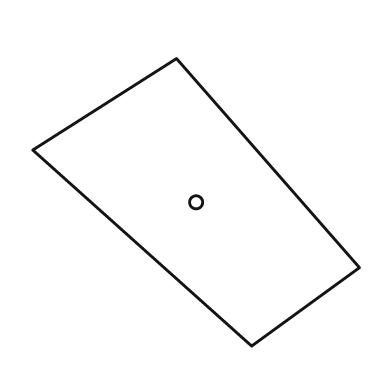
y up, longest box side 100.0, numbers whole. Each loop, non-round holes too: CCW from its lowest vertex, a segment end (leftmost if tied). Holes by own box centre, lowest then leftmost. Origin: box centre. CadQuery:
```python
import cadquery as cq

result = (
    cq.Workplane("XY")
    .moveTo(17.0, -44.0)
    .lineTo(50.0, -20.0)
    .lineTo(-6.0, 44.0)
    .lineTo(-50.0, 16.0)
    .close()
    .moveTo(0.0, 0.0)
    .circle(2.0)
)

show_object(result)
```